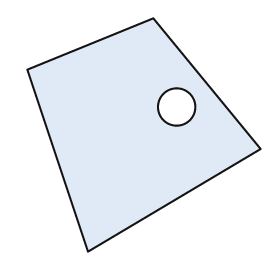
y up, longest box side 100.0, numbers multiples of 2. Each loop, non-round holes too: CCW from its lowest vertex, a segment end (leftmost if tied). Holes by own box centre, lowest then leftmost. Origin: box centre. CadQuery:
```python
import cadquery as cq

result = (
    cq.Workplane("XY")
    .moveTo(-24.0, -50.0)
    .lineTo(50.0, -6.0)
    .lineTo(4.0, 50.0)
    .lineTo(-50.0, 28.0)
    .close()
    .moveTo(14.0, 12.0)
    .circle(8.0)
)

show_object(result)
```